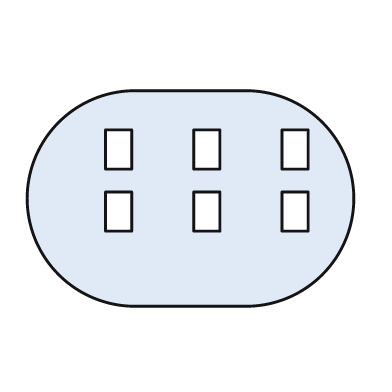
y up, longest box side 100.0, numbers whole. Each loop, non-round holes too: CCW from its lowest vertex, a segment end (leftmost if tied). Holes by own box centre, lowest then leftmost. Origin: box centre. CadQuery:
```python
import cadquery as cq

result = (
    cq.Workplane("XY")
    .moveTo(-17.0, -33.0)
    .lineTo(17.0, -33.0)
    .threePointArc((50.0, 0.0), (17.0, 33.0))
    .lineTo(-17.0, 33.0)
    .threePointArc((-50.0, 0.0), (-17.0, -33.0))
    .close()
    .moveTo(-26.0, -10.0)
    .lineTo(-18.0, -10.0)
    .lineTo(-18.0, 2.0)
    .lineTo(-26.0, 2.0)
    .close()
    .moveTo(1.0, -10.0)
    .lineTo(9.0, -10.0)
    .lineTo(9.0, 2.0)
    .lineTo(1.0, 2.0)
    .close()
    .moveTo(28.0, -10.0)
    .lineTo(36.0, -10.0)
    .lineTo(36.0, 2.0)
    .lineTo(28.0, 2.0)
    .close()
    .moveTo(-26.0, 9.0)
    .lineTo(-18.0, 9.0)
    .lineTo(-18.0, 21.0)
    .lineTo(-26.0, 21.0)
    .close()
    .moveTo(1.0, 9.0)
    .lineTo(9.0, 9.0)
    .lineTo(9.0, 21.0)
    .lineTo(1.0, 21.0)
    .close()
    .moveTo(28.0, 9.0)
    .lineTo(36.0, 9.0)
    .lineTo(36.0, 21.0)
    .lineTo(28.0, 21.0)
    .close()
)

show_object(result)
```